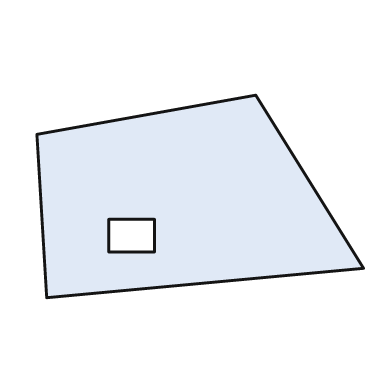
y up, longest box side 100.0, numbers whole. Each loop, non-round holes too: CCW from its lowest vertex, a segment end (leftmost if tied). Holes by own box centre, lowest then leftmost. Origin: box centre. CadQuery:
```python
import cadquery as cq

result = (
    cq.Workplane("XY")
    .moveTo(-47.0, -31.0)
    .lineTo(50.0, -22.0)
    .lineTo(17.0, 31.0)
    .lineTo(-50.0, 19.0)
    .close()
    .moveTo(-28.0, -17.0)
    .lineTo(-14.0, -17.0)
    .lineTo(-14.0, -7.0)
    .lineTo(-28.0, -7.0)
    .close()
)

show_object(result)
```